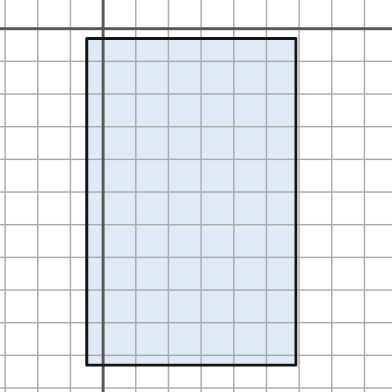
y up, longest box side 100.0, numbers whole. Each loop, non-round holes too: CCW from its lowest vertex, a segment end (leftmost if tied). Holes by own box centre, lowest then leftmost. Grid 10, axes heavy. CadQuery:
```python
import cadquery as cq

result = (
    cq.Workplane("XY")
    .moveTo(-5.0, -103.0)
    .lineTo(59.0, -103.0)
    .lineTo(59.0, -3.0)
    .lineTo(-5.0, -3.0)
    .close()
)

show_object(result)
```